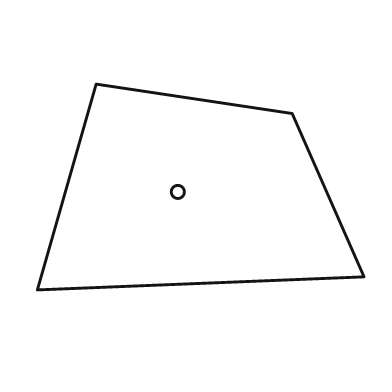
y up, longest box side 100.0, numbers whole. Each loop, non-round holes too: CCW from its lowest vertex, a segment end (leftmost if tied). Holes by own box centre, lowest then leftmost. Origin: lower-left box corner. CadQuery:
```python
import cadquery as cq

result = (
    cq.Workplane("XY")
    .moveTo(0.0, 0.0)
    .lineTo(100.0, 4.0)
    .lineTo(78.0, 54.0)
    .lineTo(18.0, 63.0)
    .close()
    .moveTo(43.0, 30.0)
    .circle(2.0)
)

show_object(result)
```